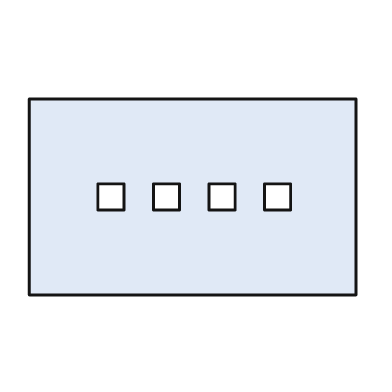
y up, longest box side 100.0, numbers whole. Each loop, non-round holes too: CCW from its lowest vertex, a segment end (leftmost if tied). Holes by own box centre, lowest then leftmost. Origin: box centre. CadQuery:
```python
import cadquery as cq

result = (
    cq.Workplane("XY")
    .moveTo(-50.0, -30.0)
    .lineTo(50.0, -30.0)
    .lineTo(50.0, 30.0)
    .lineTo(-50.0, 30.0)
    .close()
    .moveTo(-29.0, -4.0)
    .lineTo(-21.0, -4.0)
    .lineTo(-21.0, 4.0)
    .lineTo(-29.0, 4.0)
    .close()
    .moveTo(-12.0, -4.0)
    .lineTo(-4.0, -4.0)
    .lineTo(-4.0, 4.0)
    .lineTo(-12.0, 4.0)
    .close()
    .moveTo(5.0, -4.0)
    .lineTo(13.0, -4.0)
    .lineTo(13.0, 4.0)
    .lineTo(5.0, 4.0)
    .close()
    .moveTo(22.0, -4.0)
    .lineTo(30.0, -4.0)
    .lineTo(30.0, 4.0)
    .lineTo(22.0, 4.0)
    .close()
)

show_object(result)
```